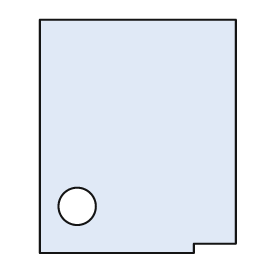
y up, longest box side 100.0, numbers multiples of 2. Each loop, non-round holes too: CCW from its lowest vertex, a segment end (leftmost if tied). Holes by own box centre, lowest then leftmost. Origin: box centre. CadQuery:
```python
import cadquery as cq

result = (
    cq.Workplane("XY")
    .moveTo(-42.0, -50.0)
    .lineTo(24.0, -50.0)
    .lineTo(24.0, -46.0)
    .lineTo(42.0, -46.0)
    .lineTo(42.0, 50.0)
    .lineTo(-42.0, 50.0)
    .close()
    .moveTo(-26.0, -30.0)
    .circle(8.0)
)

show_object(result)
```